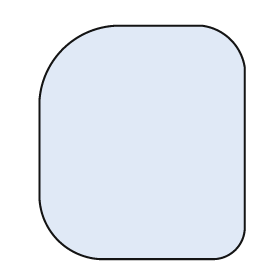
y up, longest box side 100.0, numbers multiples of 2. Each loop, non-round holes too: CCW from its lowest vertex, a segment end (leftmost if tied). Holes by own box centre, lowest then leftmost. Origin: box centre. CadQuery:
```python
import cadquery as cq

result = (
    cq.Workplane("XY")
    .moveTo(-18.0, -50.0)
    .lineTo(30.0, -50.0)
    .threePointArc((40.0, -46.0), (44.0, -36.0))
    .lineTo(44.0, 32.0)
    .threePointArc((38.0, 44.0), (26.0, 50.0))
    .lineTo(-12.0, 50.0)
    .threePointArc((-34.0, 40.0), (-44.0, 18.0))
    .lineTo(-44.0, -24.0)
    .threePointArc((-36.0, -42.0), (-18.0, -50.0))
    .close()
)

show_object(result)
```